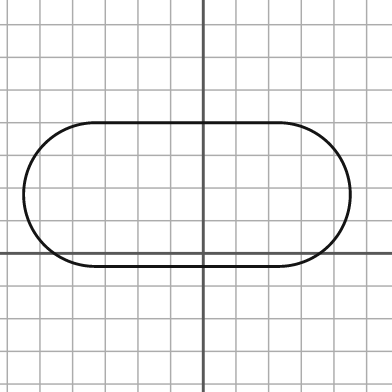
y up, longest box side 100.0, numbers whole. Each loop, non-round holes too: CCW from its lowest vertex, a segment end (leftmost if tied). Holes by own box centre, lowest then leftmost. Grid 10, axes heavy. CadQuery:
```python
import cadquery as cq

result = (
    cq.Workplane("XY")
    .moveTo(-33.0, -4.0)
    .lineTo(23.0, -4.0)
    .threePointArc((45.0, 18.0), (23.0, 40.0))
    .lineTo(-33.0, 40.0)
    .threePointArc((-55.0, 18.0), (-33.0, -4.0))
    .close()
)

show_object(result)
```